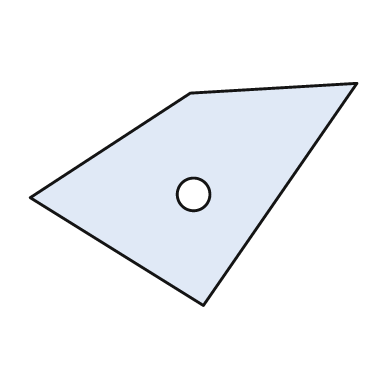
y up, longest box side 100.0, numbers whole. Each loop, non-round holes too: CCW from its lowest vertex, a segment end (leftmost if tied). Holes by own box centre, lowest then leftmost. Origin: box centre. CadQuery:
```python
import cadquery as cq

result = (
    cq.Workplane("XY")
    .moveTo(3.0, -34.0)
    .lineTo(50.0, 34.0)
    .lineTo(-1.0, 31.0)
    .lineTo(-50.0, -1.0)
    .close()
    .moveTo(0.0, 0.0)
    .circle(5.0)
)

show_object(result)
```